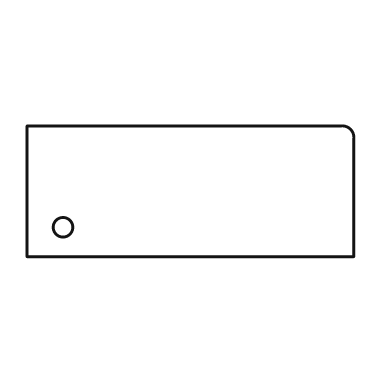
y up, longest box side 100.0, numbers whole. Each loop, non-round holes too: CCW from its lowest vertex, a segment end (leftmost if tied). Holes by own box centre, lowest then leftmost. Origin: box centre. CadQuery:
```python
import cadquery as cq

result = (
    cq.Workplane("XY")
    .moveTo(-50.0, -20.0)
    .lineTo(50.0, -20.0)
    .lineTo(50.0, 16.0)
    .threePointArc((49.0, 19.0), (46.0, 20.0))
    .lineTo(-50.0, 20.0)
    .close()
    .moveTo(-39.0, -11.0)
    .circle(3.0)
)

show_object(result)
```